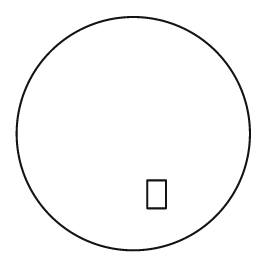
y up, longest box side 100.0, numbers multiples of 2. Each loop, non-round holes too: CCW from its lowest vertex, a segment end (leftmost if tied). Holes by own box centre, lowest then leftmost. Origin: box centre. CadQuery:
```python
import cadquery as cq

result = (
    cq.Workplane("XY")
    .moveTo(0.0, 0.0)
    .circle(50.0)
    .moveTo(6.0, -32.0)
    .lineTo(14.0, -32.0)
    .lineTo(14.0, -20.0)
    .lineTo(6.0, -20.0)
    .close()
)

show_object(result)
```